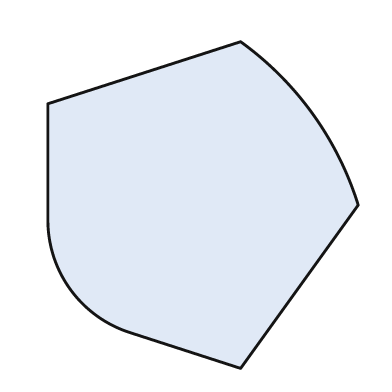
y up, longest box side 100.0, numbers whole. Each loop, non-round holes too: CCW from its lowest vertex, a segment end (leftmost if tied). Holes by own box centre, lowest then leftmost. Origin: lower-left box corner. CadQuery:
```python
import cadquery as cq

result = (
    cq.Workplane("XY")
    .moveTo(59.0, 0.0)
    .lineTo(95.0, 50.0)
    .threePointArc((81.0, 78.0), (59.0, 100.0))
    .lineTo(0.0, 81.0)
    .lineTo(0.0, 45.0)
    .threePointArc((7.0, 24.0), (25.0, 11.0))
    .close()
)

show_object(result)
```